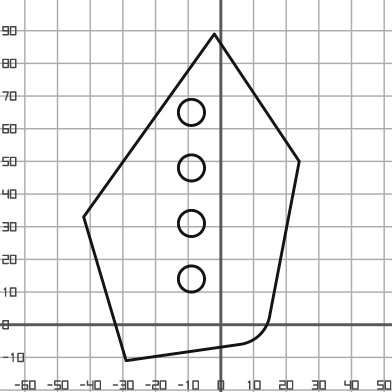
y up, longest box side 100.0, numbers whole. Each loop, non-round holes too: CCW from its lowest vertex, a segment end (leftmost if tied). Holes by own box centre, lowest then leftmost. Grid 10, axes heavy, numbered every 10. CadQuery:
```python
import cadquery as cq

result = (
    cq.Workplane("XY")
    .moveTo(-29.0, -11.0)
    .lineTo(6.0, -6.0)
    .threePointArc((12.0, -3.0), (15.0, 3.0))
    .lineTo(24.0, 50.0)
    .lineTo(-2.0, 89.0)
    .lineTo(-42.0, 33.0)
    .close()
    .moveTo(-9.0, 14.0)
    .circle(4.0)
    .moveTo(-9.0, 31.0)
    .circle(4.0)
    .moveTo(-9.0, 48.0)
    .circle(4.0)
    .moveTo(-9.0, 65.0)
    .circle(4.0)
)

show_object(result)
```